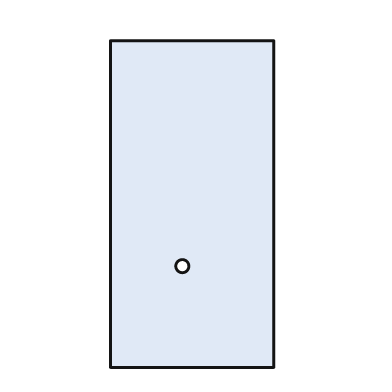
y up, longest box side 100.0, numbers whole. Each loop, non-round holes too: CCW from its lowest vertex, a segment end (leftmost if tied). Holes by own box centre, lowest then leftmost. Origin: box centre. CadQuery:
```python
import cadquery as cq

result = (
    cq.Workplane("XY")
    .moveTo(-25.0, -50.0)
    .lineTo(25.0, -50.0)
    .lineTo(25.0, 50.0)
    .lineTo(-25.0, 50.0)
    .close()
    .moveTo(-3.0, -19.0)
    .circle(2.0)
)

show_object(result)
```